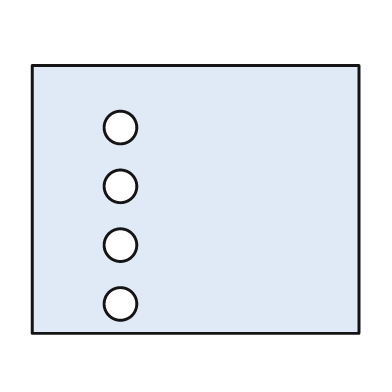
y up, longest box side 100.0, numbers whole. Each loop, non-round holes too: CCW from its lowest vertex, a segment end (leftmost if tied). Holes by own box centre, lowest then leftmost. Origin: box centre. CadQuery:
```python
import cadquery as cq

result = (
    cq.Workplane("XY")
    .moveTo(-50.0, -41.0)
    .lineTo(50.0, -41.0)
    .lineTo(50.0, 41.0)
    .lineTo(-50.0, 41.0)
    .close()
    .moveTo(-23.0, -32.0)
    .circle(5.0)
    .moveTo(-23.0, -14.0)
    .circle(5.0)
    .moveTo(-23.0, 4.0)
    .circle(5.0)
    .moveTo(-23.0, 22.0)
    .circle(5.0)
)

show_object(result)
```